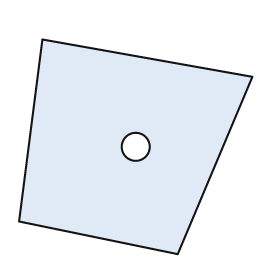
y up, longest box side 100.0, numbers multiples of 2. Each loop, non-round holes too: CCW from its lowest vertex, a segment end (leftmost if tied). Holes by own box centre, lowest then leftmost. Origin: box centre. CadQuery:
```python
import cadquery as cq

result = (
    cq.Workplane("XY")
    .moveTo(18.0, -46.0)
    .lineTo(50.0, 30.0)
    .lineTo(-40.0, 46.0)
    .lineTo(-50.0, -32.0)
    .close()
    .moveTo(0.0, 0.0)
    .circle(6.0)
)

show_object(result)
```